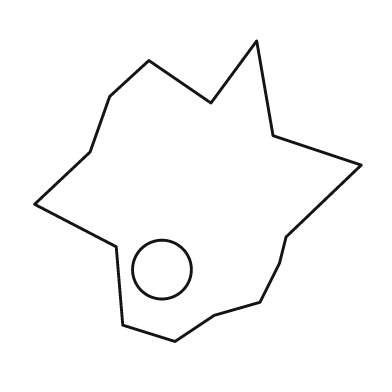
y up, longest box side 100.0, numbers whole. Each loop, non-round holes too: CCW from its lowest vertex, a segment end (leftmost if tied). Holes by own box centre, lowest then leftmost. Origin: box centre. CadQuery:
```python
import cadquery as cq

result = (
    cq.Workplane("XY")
    .moveTo(-7.0, -46.0)
    .lineTo(5.0, -38.0)
    .lineTo(19.0, -34.0)
    .lineTo(25.0, -22.0)
    .lineTo(27.0, -14.0)
    .lineTo(50.0, 8.0)
    .lineTo(23.0, 17.0)
    .lineTo(18.0, 46.0)
    .lineTo(4.0, 27.0)
    .lineTo(-15.0, 40.0)
    .lineTo(-27.0, 29.0)
    .lineTo(-33.0, 12.0)
    .lineTo(-50.0, -4.0)
    .lineTo(-25.0, -17.0)
    .lineTo(-23.0, -41.0)
    .close()
    .moveTo(-11.0, -24.0)
    .circle(9.0)
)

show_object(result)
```